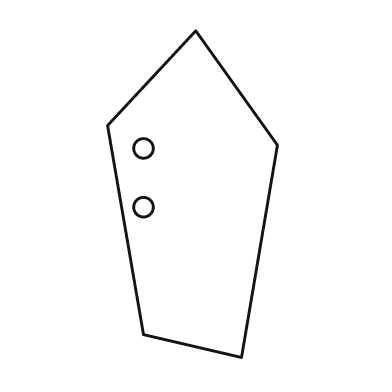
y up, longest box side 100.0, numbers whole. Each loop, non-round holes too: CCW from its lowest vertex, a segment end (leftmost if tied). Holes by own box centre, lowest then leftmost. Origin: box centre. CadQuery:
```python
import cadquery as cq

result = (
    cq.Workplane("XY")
    .moveTo(15.0, -50.0)
    .lineTo(26.0, 15.0)
    .lineTo(1.0, 50.0)
    .lineTo(-26.0, 21.0)
    .lineTo(-15.0, -43.0)
    .close()
    .moveTo(-15.0, -4.0)
    .circle(3.0)
    .moveTo(-15.0, 14.0)
    .circle(3.0)
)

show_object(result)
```